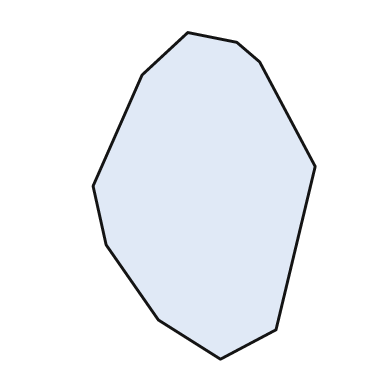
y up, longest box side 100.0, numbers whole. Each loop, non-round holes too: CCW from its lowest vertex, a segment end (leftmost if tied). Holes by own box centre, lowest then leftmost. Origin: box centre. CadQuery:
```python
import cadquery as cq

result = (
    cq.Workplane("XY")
    .moveTo(5.0, -50.0)
    .lineTo(22.0, -41.0)
    .lineTo(34.0, 9.0)
    .lineTo(17.0, 41.0)
    .lineTo(10.0, 47.0)
    .lineTo(-5.0, 50.0)
    .lineTo(-19.0, 37.0)
    .lineTo(-34.0, 3.0)
    .lineTo(-30.0, -15.0)
    .lineTo(-14.0, -38.0)
    .close()
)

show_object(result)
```